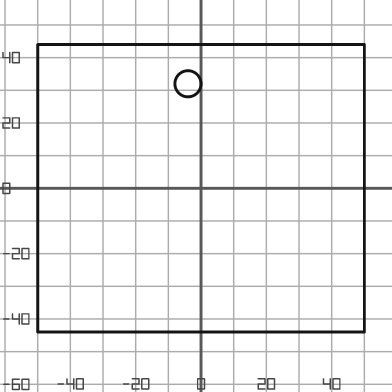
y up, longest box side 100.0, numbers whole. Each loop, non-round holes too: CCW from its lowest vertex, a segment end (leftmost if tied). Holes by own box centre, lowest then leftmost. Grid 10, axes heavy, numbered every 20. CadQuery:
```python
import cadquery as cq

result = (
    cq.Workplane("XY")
    .moveTo(-50.0, -44.0)
    .lineTo(50.0, -44.0)
    .lineTo(50.0, 44.0)
    .lineTo(-50.0, 44.0)
    .close()
    .moveTo(-4.0, 32.0)
    .circle(4.0)
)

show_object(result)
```